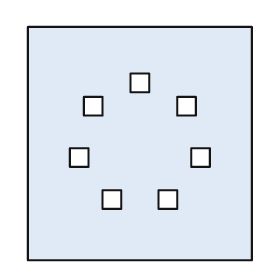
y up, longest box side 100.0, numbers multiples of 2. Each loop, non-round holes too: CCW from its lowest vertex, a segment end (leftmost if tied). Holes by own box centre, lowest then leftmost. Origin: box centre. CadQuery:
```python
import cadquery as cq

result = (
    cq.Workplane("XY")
    .moveTo(-48.0, -50.0)
    .lineTo(48.0, -50.0)
    .lineTo(48.0, 50.0)
    .lineTo(-48.0, 50.0)
    .close()
    .moveTo(-16.0, -28.0)
    .lineTo(-8.0, -28.0)
    .lineTo(-8.0, -20.0)
    .lineTo(-16.0, -20.0)
    .close()
    .moveTo(8.0, -28.0)
    .lineTo(16.0, -28.0)
    .lineTo(16.0, -20.0)
    .lineTo(8.0, -20.0)
    .close()
    .moveTo(-30.0, -10.0)
    .lineTo(-22.0, -10.0)
    .lineTo(-22.0, -2.0)
    .lineTo(-30.0, -2.0)
    .close()
    .moveTo(22.0, -10.0)
    .lineTo(30.0, -10.0)
    .lineTo(30.0, -2.0)
    .lineTo(22.0, -2.0)
    .close()
    .moveTo(-24.0, 12.0)
    .lineTo(-16.0, 12.0)
    .lineTo(-16.0, 20.0)
    .lineTo(-24.0, 20.0)
    .close()
    .moveTo(16.0, 12.0)
    .lineTo(24.0, 12.0)
    .lineTo(24.0, 20.0)
    .lineTo(16.0, 20.0)
    .close()
    .moveTo(-4.0, 22.0)
    .lineTo(4.0, 22.0)
    .lineTo(4.0, 30.0)
    .lineTo(-4.0, 30.0)
    .close()
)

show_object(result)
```